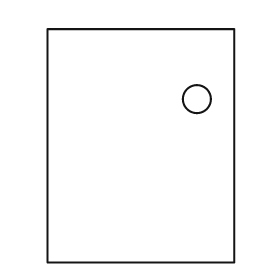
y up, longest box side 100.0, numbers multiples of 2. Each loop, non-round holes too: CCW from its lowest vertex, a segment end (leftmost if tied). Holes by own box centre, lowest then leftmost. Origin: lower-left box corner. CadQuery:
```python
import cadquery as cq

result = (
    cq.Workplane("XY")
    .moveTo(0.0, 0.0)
    .lineTo(80.0, 0.0)
    .lineTo(80.0, 100.0)
    .lineTo(0.0, 100.0)
    .close()
    .moveTo(64.0, 70.0)
    .circle(6.0)
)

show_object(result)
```